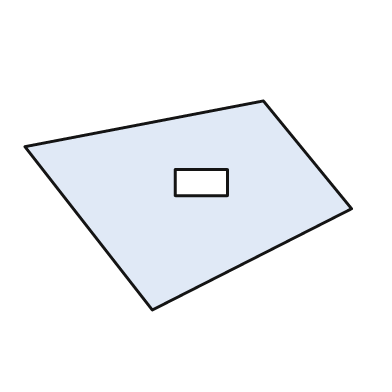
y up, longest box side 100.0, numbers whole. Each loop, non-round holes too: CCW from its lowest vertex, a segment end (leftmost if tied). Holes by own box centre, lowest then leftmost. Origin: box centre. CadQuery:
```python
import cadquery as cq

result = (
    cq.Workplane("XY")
    .moveTo(-11.0, -32.0)
    .lineTo(50.0, -1.0)
    .lineTo(23.0, 32.0)
    .lineTo(-50.0, 18.0)
    .close()
    .moveTo(-4.0, 3.0)
    .lineTo(12.0, 3.0)
    .lineTo(12.0, 11.0)
    .lineTo(-4.0, 11.0)
    .close()
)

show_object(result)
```